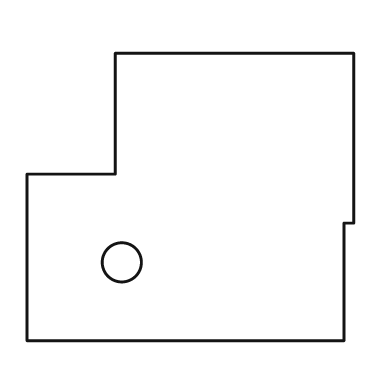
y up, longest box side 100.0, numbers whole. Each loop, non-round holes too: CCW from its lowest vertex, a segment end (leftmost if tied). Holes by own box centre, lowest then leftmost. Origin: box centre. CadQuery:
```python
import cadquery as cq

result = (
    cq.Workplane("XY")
    .moveTo(-50.0, -44.0)
    .lineTo(47.0, -44.0)
    .lineTo(47.0, -8.0)
    .lineTo(50.0, -8.0)
    .lineTo(50.0, 44.0)
    .lineTo(-23.0, 44.0)
    .lineTo(-23.0, 7.0)
    .lineTo(-50.0, 7.0)
    .close()
    .moveTo(-21.0, -20.0)
    .circle(6.0)
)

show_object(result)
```